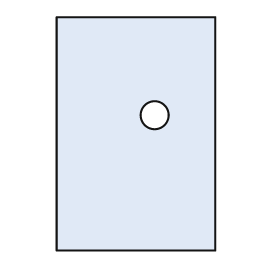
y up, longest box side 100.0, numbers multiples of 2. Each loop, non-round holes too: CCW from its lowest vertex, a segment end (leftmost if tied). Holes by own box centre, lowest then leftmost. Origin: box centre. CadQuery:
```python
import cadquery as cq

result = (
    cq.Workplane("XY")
    .moveTo(-34.0, -50.0)
    .lineTo(34.0, -50.0)
    .lineTo(34.0, 50.0)
    .lineTo(-34.0, 50.0)
    .close()
    .moveTo(8.0, 8.0)
    .circle(6.0)
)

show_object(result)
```